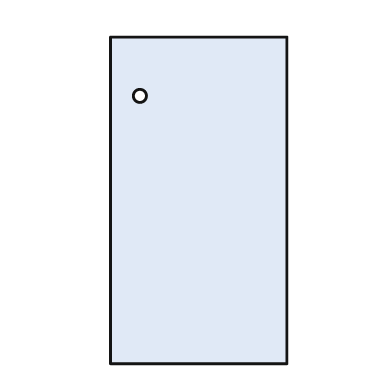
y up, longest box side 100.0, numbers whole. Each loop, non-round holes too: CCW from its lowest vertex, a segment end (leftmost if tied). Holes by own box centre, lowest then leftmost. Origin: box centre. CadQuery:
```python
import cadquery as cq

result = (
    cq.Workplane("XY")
    .moveTo(-27.0, -50.0)
    .lineTo(27.0, -50.0)
    .lineTo(27.0, 50.0)
    .lineTo(-27.0, 50.0)
    .close()
    .moveTo(-18.0, 32.0)
    .circle(2.0)
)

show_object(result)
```